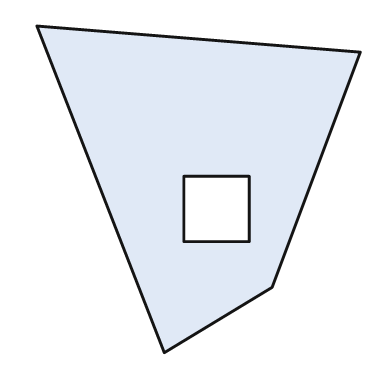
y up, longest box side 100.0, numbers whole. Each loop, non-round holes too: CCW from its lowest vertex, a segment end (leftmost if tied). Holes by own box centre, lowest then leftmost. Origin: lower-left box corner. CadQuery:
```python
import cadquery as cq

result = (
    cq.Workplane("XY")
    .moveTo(39.0, 0.0)
    .lineTo(72.0, 20.0)
    .lineTo(99.0, 92.0)
    .lineTo(0.0, 100.0)
    .close()
    .moveTo(45.0, 34.0)
    .lineTo(65.0, 34.0)
    .lineTo(65.0, 54.0)
    .lineTo(45.0, 54.0)
    .close()
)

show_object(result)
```